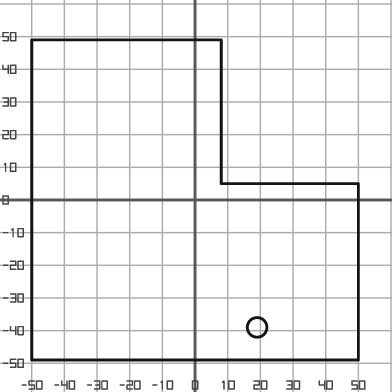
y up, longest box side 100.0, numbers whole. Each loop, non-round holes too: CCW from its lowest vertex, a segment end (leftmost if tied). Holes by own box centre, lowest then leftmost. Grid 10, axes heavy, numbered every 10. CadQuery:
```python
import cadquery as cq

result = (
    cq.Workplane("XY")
    .moveTo(-50.0, -49.0)
    .lineTo(50.0, -49.0)
    .lineTo(50.0, 5.0)
    .lineTo(8.0, 5.0)
    .lineTo(8.0, 49.0)
    .lineTo(-50.0, 49.0)
    .close()
    .moveTo(19.0, -39.0)
    .circle(3.0)
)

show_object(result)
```